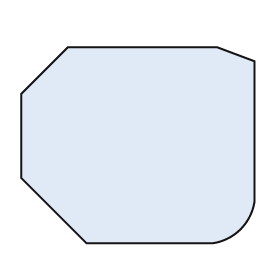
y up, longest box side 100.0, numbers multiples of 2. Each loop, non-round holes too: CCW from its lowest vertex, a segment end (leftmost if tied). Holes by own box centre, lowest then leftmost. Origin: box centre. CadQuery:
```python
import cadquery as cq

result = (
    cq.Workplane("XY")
    .moveTo(-22.0, -42.0)
    .lineTo(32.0, -42.0)
    .threePointArc((44.0, -36.0), (50.0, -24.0))
    .lineTo(50.0, 36.0)
    .lineTo(34.0, 42.0)
    .lineTo(-30.0, 42.0)
    .lineTo(-50.0, 22.0)
    .lineTo(-50.0, -14.0)
    .close()
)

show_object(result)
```